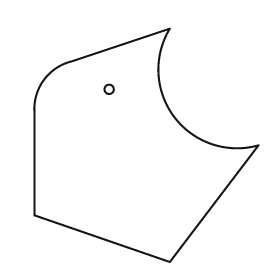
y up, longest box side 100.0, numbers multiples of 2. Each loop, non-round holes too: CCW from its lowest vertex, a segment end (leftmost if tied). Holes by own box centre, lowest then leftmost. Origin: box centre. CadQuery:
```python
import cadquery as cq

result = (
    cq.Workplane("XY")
    .moveTo(10.0, -50.0)
    .lineTo(48.0, 0.0)
    .threePointArc((12.0, 12.0), (10.0, 50.0))
    .lineTo(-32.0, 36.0)
    .threePointArc((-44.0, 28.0), (-48.0, 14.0))
    .lineTo(-48.0, -30.0)
    .close()
    .moveTo(-16.0, 24.0)
    .circle(2.0)
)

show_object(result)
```